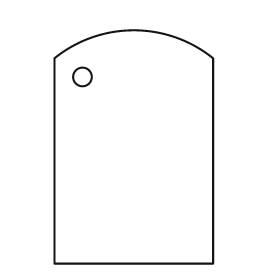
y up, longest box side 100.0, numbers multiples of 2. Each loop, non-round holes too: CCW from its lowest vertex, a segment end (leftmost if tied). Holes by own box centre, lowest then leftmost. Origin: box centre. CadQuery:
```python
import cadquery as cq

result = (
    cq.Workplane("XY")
    .moveTo(-34.0, -50.0)
    .lineTo(34.0, -50.0)
    .lineTo(34.0, 38.0)
    .threePointArc((0.0, 50.0), (-34.0, 38.0))
    .close()
    .moveTo(-22.0, 30.0)
    .circle(4.0)
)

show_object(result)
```